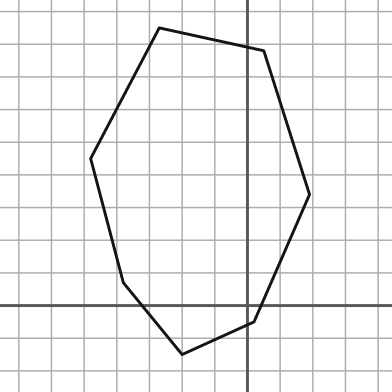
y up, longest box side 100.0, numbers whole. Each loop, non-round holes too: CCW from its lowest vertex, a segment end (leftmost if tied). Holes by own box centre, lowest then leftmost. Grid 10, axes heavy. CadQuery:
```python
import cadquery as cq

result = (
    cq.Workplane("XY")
    .moveTo(-20.0, -15.0)
    .lineTo(2.0, -5.0)
    .lineTo(19.0, 34.0)
    .lineTo(5.0, 78.0)
    .lineTo(-27.0, 85.0)
    .lineTo(-48.0, 45.0)
    .lineTo(-38.0, 7.0)
    .close()
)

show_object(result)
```